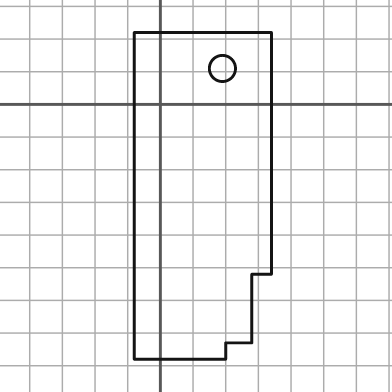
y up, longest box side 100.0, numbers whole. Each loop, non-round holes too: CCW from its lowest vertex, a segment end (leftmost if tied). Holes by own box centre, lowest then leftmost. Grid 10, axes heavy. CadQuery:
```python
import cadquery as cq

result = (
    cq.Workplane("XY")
    .moveTo(-8.0, -78.0)
    .lineTo(20.0, -78.0)
    .lineTo(20.0, -73.0)
    .lineTo(28.0, -73.0)
    .lineTo(28.0, -52.0)
    .lineTo(34.0, -52.0)
    .lineTo(34.0, 22.0)
    .lineTo(-8.0, 22.0)
    .close()
    .moveTo(19.0, 11.0)
    .circle(4.0)
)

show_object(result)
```